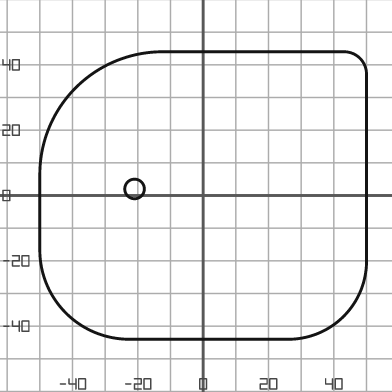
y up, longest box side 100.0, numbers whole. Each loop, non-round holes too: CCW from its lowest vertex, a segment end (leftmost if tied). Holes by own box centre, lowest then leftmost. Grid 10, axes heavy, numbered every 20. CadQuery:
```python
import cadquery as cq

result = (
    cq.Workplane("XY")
    .moveTo(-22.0, -44.0)
    .lineTo(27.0, -44.0)
    .threePointArc((43.0, -37.0), (50.0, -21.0))
    .lineTo(50.0, 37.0)
    .threePointArc((48.0, 42.0), (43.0, 44.0))
    .lineTo(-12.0, 44.0)
    .threePointArc((-39.0, 33.0), (-50.0, 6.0))
    .lineTo(-50.0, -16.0)
    .threePointArc((-42.0, -36.0), (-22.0, -44.0))
    .close()
    .moveTo(-21.0, 2.0)
    .circle(3.0)
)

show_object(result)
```